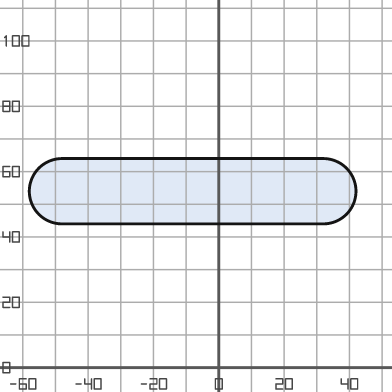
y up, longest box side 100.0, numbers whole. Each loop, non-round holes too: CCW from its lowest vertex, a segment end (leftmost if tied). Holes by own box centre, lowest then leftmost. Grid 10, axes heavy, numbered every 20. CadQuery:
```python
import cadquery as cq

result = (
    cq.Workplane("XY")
    .moveTo(-48.0, 44.0)
    .lineTo(32.0, 44.0)
    .threePointArc((42.0, 54.0), (32.0, 64.0))
    .lineTo(-48.0, 64.0)
    .threePointArc((-58.0, 54.0), (-48.0, 44.0))
    .close()
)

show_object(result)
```